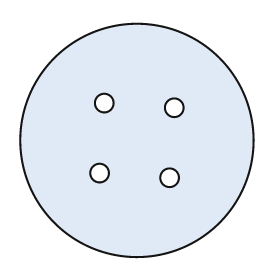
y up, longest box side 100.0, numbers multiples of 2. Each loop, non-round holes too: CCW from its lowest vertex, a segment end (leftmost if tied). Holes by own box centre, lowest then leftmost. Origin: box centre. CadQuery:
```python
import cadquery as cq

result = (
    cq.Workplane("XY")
    .moveTo(0.0, 0.0)
    .circle(50.0)
    .moveTo(14.0, -16.0)
    .circle(4.0)
    .moveTo(-16.0, -14.0)
    .circle(4.0)
    .moveTo(16.0, 14.0)
    .circle(4.0)
    .moveTo(-14.0, 16.0)
    .circle(4.0)
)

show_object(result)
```